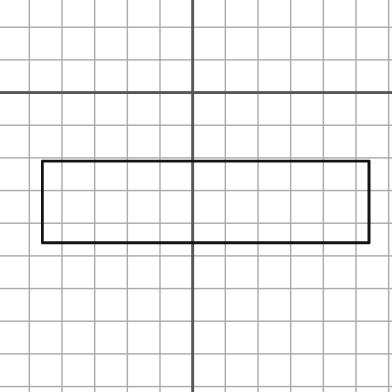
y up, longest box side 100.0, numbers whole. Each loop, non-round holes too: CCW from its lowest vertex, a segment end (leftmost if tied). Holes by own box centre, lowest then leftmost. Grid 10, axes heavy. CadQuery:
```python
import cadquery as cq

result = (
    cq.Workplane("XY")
    .moveTo(-46.0, -46.0)
    .lineTo(54.0, -46.0)
    .lineTo(54.0, -21.0)
    .lineTo(-46.0, -21.0)
    .close()
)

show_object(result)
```